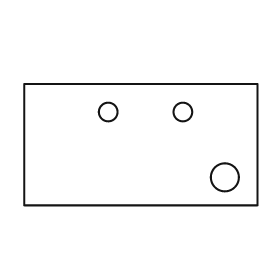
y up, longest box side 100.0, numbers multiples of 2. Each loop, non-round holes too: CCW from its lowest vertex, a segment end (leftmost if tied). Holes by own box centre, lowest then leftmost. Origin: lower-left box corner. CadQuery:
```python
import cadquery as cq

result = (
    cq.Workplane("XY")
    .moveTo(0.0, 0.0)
    .lineTo(100.0, 0.0)
    .lineTo(100.0, 52.0)
    .lineTo(0.0, 52.0)
    .close()
    .moveTo(86.0, 12.0)
    .circle(6.0)
    .moveTo(36.0, 40.0)
    .circle(4.0)
    .moveTo(68.0, 40.0)
    .circle(4.0)
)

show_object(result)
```